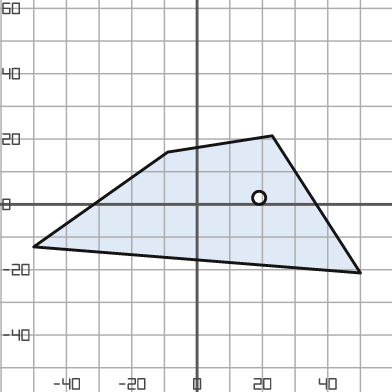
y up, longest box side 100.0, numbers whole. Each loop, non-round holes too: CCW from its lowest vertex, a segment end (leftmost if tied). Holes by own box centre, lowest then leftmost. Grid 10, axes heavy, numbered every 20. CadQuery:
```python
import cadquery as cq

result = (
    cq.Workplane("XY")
    .moveTo(50.0, -21.0)
    .lineTo(23.0, 21.0)
    .lineTo(-9.0, 16.0)
    .lineTo(-50.0, -13.0)
    .close()
    .moveTo(19.0, 2.0)
    .circle(2.0)
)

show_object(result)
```